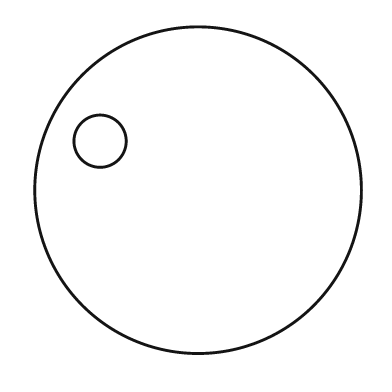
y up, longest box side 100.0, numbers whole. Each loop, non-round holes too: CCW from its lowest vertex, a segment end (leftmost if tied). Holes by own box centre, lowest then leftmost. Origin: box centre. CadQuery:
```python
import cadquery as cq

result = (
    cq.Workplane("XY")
    .moveTo(0.0, 0.0)
    .circle(50.0)
    .moveTo(-30.0, 15.0)
    .circle(8.0)
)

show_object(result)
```